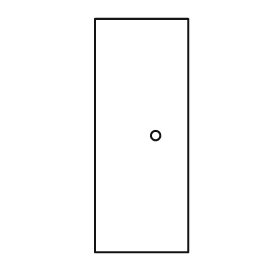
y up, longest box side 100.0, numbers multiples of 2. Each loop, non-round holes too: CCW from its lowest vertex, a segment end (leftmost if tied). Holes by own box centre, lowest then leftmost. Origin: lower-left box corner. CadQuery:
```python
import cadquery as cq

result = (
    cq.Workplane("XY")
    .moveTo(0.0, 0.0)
    .lineTo(40.0, 0.0)
    .lineTo(40.0, 100.0)
    .lineTo(0.0, 100.0)
    .close()
    .moveTo(26.0, 50.0)
    .circle(2.0)
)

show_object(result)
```